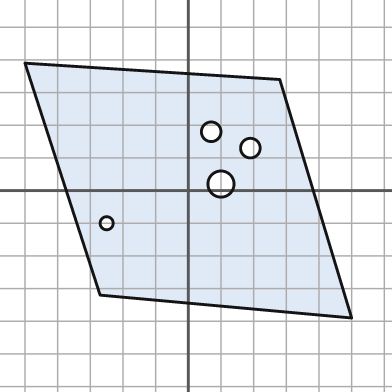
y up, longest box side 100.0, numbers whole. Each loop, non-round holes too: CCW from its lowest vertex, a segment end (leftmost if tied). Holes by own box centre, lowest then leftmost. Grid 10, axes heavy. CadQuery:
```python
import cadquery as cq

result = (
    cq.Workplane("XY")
    .moveTo(50.0, -39.0)
    .lineTo(28.0, 34.0)
    .lineTo(-50.0, 39.0)
    .lineTo(-27.0, -32.0)
    .close()
    .moveTo(-25.0, -10.0)
    .circle(2.0)
    .moveTo(10.0, 2.0)
    .circle(4.0)
    .moveTo(19.0, 13.0)
    .circle(3.0)
    .moveTo(7.0, 18.0)
    .circle(3.0)
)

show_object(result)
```